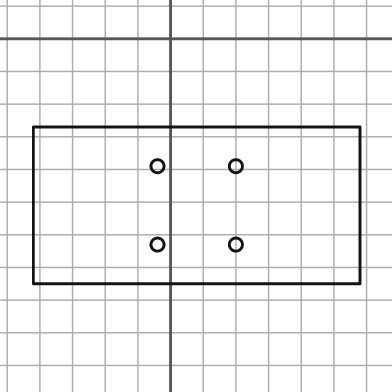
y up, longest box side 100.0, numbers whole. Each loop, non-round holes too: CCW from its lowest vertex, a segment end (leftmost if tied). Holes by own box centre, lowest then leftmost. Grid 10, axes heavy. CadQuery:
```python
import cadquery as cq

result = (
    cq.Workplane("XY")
    .moveTo(-42.0, -75.0)
    .lineTo(58.0, -75.0)
    .lineTo(58.0, -27.0)
    .lineTo(-42.0, -27.0)
    .close()
    .moveTo(-4.0, -63.0)
    .circle(2.0)
    .moveTo(20.0, -63.0)
    .circle(2.0)
    .moveTo(-4.0, -39.0)
    .circle(2.0)
    .moveTo(20.0, -39.0)
    .circle(2.0)
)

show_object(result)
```